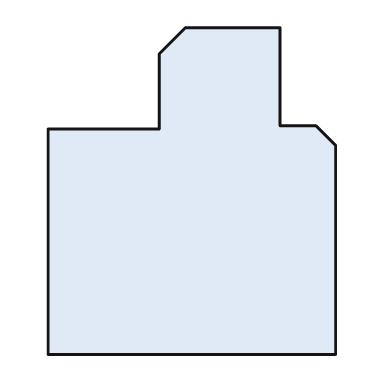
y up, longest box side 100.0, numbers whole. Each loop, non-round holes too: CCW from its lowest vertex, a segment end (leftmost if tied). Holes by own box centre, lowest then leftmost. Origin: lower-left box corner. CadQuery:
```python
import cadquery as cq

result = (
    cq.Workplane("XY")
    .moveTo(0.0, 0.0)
    .lineTo(88.0, 0.0)
    .lineTo(88.0, 64.0)
    .lineTo(82.0, 70.0)
    .lineTo(71.0, 70.0)
    .lineTo(71.0, 100.0)
    .lineTo(42.0, 100.0)
    .lineTo(34.0, 92.0)
    .lineTo(34.0, 69.0)
    .lineTo(0.0, 69.0)
    .close()
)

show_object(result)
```